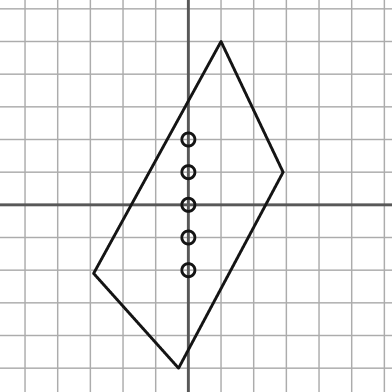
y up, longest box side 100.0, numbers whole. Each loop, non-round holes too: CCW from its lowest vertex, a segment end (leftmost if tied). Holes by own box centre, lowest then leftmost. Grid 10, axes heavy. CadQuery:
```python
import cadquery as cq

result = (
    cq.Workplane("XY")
    .moveTo(-3.0, -50.0)
    .lineTo(29.0, 10.0)
    .lineTo(10.0, 50.0)
    .lineTo(-29.0, -21.0)
    .close()
    .moveTo(0.0, -20.0)
    .circle(2.0)
    .moveTo(0.0, -10.0)
    .circle(2.0)
    .moveTo(0.0, 0.0)
    .circle(2.0)
    .moveTo(0.0, 10.0)
    .circle(2.0)
    .moveTo(0.0, 20.0)
    .circle(2.0)
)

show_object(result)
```